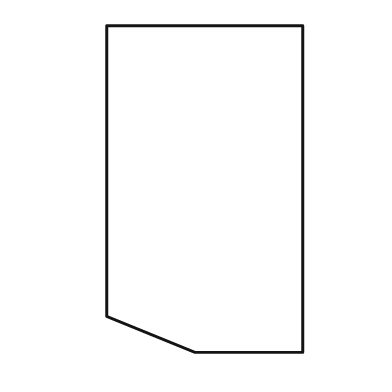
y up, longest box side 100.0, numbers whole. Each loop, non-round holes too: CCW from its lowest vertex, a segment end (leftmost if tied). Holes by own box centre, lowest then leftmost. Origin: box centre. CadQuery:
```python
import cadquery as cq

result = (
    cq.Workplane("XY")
    .moveTo(-3.0, -50.0)
    .lineTo(30.0, -50.0)
    .lineTo(30.0, 50.0)
    .lineTo(-30.0, 50.0)
    .lineTo(-30.0, -39.0)
    .close()
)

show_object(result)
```